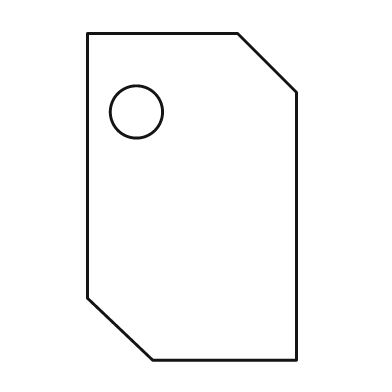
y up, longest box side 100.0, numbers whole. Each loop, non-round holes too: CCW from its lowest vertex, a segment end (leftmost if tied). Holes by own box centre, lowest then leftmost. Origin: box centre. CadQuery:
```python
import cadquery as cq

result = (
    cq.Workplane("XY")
    .moveTo(-12.0, -50.0)
    .lineTo(32.0, -50.0)
    .lineTo(32.0, 32.0)
    .lineTo(14.0, 50.0)
    .lineTo(-32.0, 50.0)
    .lineTo(-32.0, -31.0)
    .close()
    .moveTo(-17.0, 26.0)
    .circle(8.0)
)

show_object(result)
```